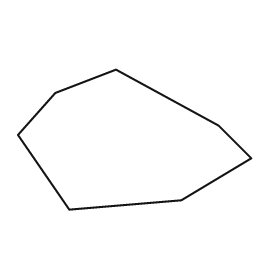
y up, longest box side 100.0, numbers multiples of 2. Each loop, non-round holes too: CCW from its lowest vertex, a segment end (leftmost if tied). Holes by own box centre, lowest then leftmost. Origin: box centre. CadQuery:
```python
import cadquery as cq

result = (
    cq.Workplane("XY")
    .moveTo(-28.0, -30.0)
    .lineTo(20.0, -26.0)
    .lineTo(50.0, -8.0)
    .lineTo(36.0, 6.0)
    .lineTo(-8.0, 30.0)
    .lineTo(-34.0, 20.0)
    .lineTo(-50.0, 2.0)
    .close()
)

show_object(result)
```